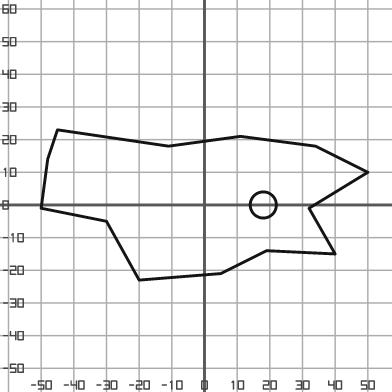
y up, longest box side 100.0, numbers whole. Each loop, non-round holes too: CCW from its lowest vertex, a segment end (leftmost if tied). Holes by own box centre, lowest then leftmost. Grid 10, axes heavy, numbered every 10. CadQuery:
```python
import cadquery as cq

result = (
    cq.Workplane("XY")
    .moveTo(-20.0, -23.0)
    .lineTo(5.0, -21.0)
    .lineTo(19.0, -14.0)
    .lineTo(40.0, -15.0)
    .lineTo(32.0, -1.0)
    .lineTo(50.0, 10.0)
    .lineTo(34.0, 18.0)
    .lineTo(11.0, 21.0)
    .lineTo(-11.0, 18.0)
    .lineTo(-45.0, 23.0)
    .lineTo(-48.0, 14.0)
    .lineTo(-50.0, -1.0)
    .lineTo(-30.0, -5.0)
    .close()
    .moveTo(18.0, 0.0)
    .circle(4.0)
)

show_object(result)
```